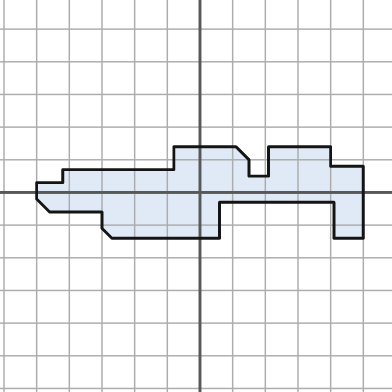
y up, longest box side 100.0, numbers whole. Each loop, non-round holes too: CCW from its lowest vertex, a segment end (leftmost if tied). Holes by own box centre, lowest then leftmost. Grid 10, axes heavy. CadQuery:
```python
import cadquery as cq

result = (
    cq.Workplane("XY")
    .moveTo(-27.0, -14.0)
    .lineTo(6.0, -14.0)
    .lineTo(6.0, -3.0)
    .lineTo(41.0, -3.0)
    .lineTo(41.0, -14.0)
    .lineTo(50.0, -14.0)
    .lineTo(50.0, 8.0)
    .lineTo(40.0, 8.0)
    .lineTo(40.0, 14.0)
    .lineTo(21.0, 14.0)
    .lineTo(21.0, 5.0)
    .lineTo(15.0, 5.0)
    .lineTo(15.0, 10.0)
    .lineTo(11.0, 14.0)
    .lineTo(-8.0, 14.0)
    .lineTo(-8.0, 7.0)
    .lineTo(-42.0, 7.0)
    .lineTo(-42.0, 3.0)
    .lineTo(-50.0, 3.0)
    .lineTo(-50.0, -2.0)
    .lineTo(-46.0, -6.0)
    .lineTo(-30.0, -6.0)
    .lineTo(-30.0, -11.0)
    .close()
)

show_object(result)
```